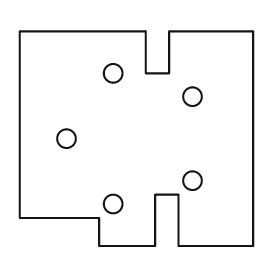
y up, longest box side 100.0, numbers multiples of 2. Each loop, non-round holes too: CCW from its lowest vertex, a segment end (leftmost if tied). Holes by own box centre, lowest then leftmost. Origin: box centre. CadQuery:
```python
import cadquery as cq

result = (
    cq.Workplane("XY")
    .moveTo(-16.0, -46.0)
    .lineTo(8.0, -46.0)
    .lineTo(8.0, -24.0)
    .lineTo(18.0, -24.0)
    .lineTo(18.0, -46.0)
    .lineTo(50.0, -46.0)
    .lineTo(50.0, 46.0)
    .lineTo(14.0, 46.0)
    .lineTo(14.0, 28.0)
    .lineTo(4.0, 28.0)
    .lineTo(4.0, 46.0)
    .lineTo(-50.0, 46.0)
    .lineTo(-50.0, -34.0)
    .lineTo(-16.0, -34.0)
    .close()
    .moveTo(-10.0, -28.0)
    .circle(4.0)
    .moveTo(24.0, -18.0)
    .circle(4.0)
    .moveTo(-30.0, 0.0)
    .circle(4.0)
    .moveTo(24.0, 18.0)
    .circle(4.0)
    .moveTo(-10.0, 28.0)
    .circle(4.0)
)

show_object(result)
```